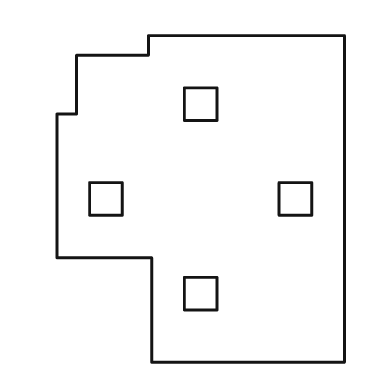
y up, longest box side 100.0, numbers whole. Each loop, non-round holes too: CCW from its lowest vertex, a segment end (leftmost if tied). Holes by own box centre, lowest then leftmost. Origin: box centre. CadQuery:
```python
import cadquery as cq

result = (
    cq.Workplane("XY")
    .moveTo(-15.0, -50.0)
    .lineTo(44.0, -50.0)
    .lineTo(44.0, 50.0)
    .lineTo(-16.0, 50.0)
    .lineTo(-16.0, 44.0)
    .lineTo(-38.0, 44.0)
    .lineTo(-38.0, 26.0)
    .lineTo(-44.0, 26.0)
    .lineTo(-44.0, -18.0)
    .lineTo(-15.0, -18.0)
    .close()
    .moveTo(-5.0, -34.0)
    .lineTo(5.0, -34.0)
    .lineTo(5.0, -24.0)
    .lineTo(-5.0, -24.0)
    .close()
    .moveTo(-34.0, -5.0)
    .lineTo(-24.0, -5.0)
    .lineTo(-24.0, 5.0)
    .lineTo(-34.0, 5.0)
    .close()
    .moveTo(24.0, -5.0)
    .lineTo(34.0, -5.0)
    .lineTo(34.0, 5.0)
    .lineTo(24.0, 5.0)
    .close()
    .moveTo(-5.0, 24.0)
    .lineTo(5.0, 24.0)
    .lineTo(5.0, 34.0)
    .lineTo(-5.0, 34.0)
    .close()
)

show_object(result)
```